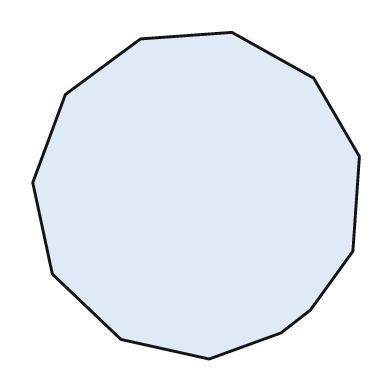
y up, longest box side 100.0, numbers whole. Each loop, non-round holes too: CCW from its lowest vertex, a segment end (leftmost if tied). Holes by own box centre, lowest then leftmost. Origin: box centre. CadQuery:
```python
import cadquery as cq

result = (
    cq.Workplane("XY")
    .moveTo(4.0, -50.0)
    .lineTo(26.0, -42.0)
    .lineTo(35.0, -35.0)
    .lineTo(48.0, -17.0)
    .lineTo(50.0, 12.0)
    .lineTo(36.0, 36.0)
    .lineTo(11.0, 50.0)
    .lineTo(-17.0, 48.0)
    .lineTo(-40.0, 31.0)
    .lineTo(-50.0, 4.0)
    .lineTo(-44.0, -24.0)
    .lineTo(-23.0, -44.0)
    .close()
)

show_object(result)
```